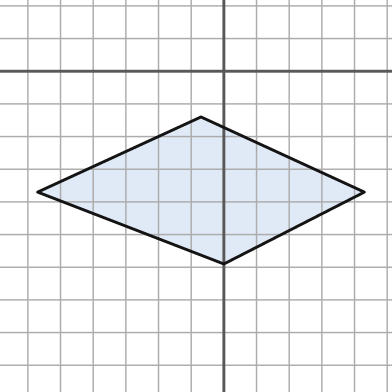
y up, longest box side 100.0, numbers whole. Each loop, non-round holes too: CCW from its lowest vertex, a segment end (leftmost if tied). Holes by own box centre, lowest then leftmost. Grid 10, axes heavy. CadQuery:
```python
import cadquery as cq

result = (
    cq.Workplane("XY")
    .moveTo(0.0, -59.0)
    .lineTo(43.0, -37.0)
    .lineTo(-7.0, -14.0)
    .lineTo(-57.0, -37.0)
    .close()
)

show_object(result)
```